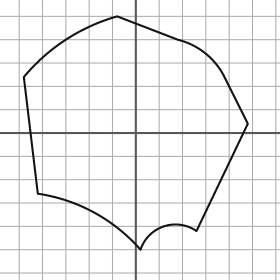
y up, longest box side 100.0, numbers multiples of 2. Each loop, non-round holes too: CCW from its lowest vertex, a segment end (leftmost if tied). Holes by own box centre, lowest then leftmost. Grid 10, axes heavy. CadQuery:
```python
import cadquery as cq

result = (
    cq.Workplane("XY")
    .moveTo(2.0, -50.0)
    .threePointArc((12.0, -40.0), (26.0, -42.0))
    .lineTo(48.0, 4.0)
    .lineTo(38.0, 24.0)
    .threePointArc((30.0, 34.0), (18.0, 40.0))
    .lineTo(-8.0, 50.0)
    .threePointArc((-30.0, 40.0), (-48.0, 24.0))
    .lineTo(-42.0, -26.0)
    .threePointArc((-18.0, -34.0), (2.0, -50.0))
    .close()
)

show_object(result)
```